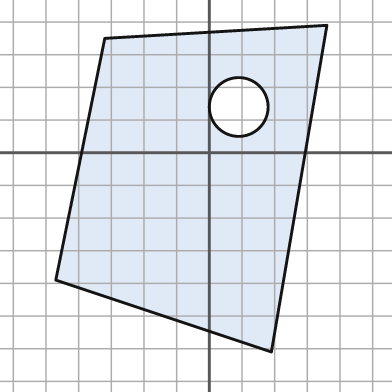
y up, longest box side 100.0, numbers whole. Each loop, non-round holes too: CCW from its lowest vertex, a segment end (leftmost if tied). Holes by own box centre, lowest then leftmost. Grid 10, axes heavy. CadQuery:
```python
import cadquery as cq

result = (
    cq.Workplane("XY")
    .moveTo(19.0, -61.0)
    .lineTo(36.0, 39.0)
    .lineTo(-32.0, 35.0)
    .lineTo(-47.0, -39.0)
    .close()
    .moveTo(9.0, 14.0)
    .circle(9.0)
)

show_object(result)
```